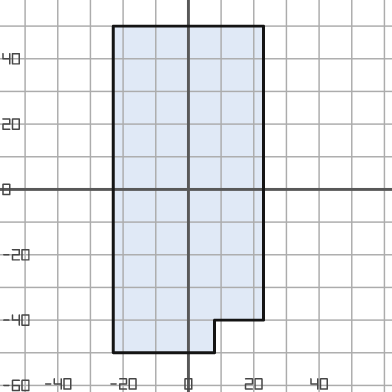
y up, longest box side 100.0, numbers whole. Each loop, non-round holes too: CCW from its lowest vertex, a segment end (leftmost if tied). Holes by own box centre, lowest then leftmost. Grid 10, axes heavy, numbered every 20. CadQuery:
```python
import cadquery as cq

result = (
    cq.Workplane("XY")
    .moveTo(-23.0, -50.0)
    .lineTo(8.0, -50.0)
    .lineTo(8.0, -40.0)
    .lineTo(23.0, -40.0)
    .lineTo(23.0, 50.0)
    .lineTo(-23.0, 50.0)
    .close()
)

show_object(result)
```